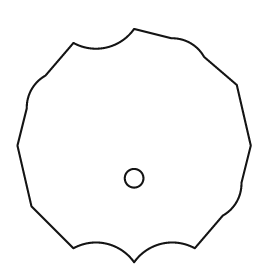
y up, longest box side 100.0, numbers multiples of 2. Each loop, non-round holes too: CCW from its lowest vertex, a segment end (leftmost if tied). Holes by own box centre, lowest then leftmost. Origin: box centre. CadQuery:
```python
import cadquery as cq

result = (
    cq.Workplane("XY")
    .moveTo(0.0, -50.0)
    .threePointArc((12.0, -42.0), (26.0, -44.0))
    .lineTo(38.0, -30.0)
    .threePointArc((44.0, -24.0), (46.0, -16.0))
    .lineTo(50.0, 0.0)
    .lineTo(44.0, 26.0)
    .lineTo(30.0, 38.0)
    .threePointArc((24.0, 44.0), (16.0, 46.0))
    .lineTo(0.0, 50.0)
    .threePointArc((-12.0, 42.0), (-26.0, 44.0))
    .lineTo(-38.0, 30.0)
    .threePointArc((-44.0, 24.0), (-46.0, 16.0))
    .lineTo(-50.0, 0.0)
    .lineTo(-44.0, -26.0)
    .lineTo(-26.0, -44.0)
    .threePointArc((-12.0, -42.0), (0.0, -50.0))
    .close()
    .moveTo(0.0, -14.0)
    .circle(4.0)
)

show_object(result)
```